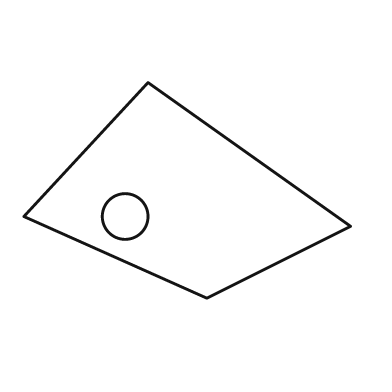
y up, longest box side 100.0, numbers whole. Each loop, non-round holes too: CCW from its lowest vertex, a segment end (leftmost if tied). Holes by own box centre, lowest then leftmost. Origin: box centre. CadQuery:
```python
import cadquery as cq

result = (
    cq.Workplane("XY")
    .moveTo(6.0, -33.0)
    .lineTo(50.0, -11.0)
    .lineTo(-12.0, 33.0)
    .lineTo(-50.0, -8.0)
    .close()
    .moveTo(-19.0, -8.0)
    .circle(7.0)
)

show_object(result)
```